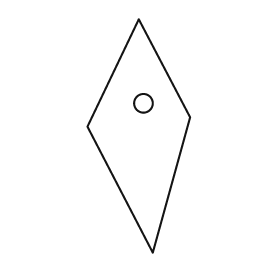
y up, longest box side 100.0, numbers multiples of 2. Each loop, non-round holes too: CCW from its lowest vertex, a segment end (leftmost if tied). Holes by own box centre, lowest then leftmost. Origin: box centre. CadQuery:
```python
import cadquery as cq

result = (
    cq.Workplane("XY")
    .moveTo(6.0, -50.0)
    .lineTo(22.0, 8.0)
    .lineTo(0.0, 50.0)
    .lineTo(-22.0, 4.0)
    .close()
    .moveTo(2.0, 14.0)
    .circle(4.0)
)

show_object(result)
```